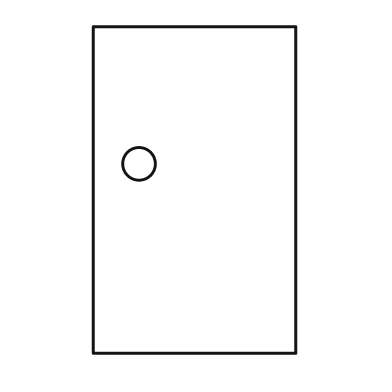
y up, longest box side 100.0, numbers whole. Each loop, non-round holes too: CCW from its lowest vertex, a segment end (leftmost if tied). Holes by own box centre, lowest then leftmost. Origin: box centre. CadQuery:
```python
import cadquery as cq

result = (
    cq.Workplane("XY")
    .moveTo(-31.0, -50.0)
    .lineTo(31.0, -50.0)
    .lineTo(31.0, 50.0)
    .lineTo(-31.0, 50.0)
    .close()
    .moveTo(-17.0, 8.0)
    .circle(5.0)
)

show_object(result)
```